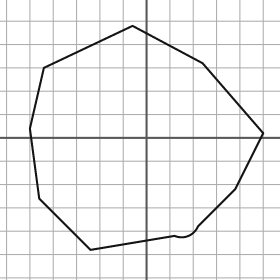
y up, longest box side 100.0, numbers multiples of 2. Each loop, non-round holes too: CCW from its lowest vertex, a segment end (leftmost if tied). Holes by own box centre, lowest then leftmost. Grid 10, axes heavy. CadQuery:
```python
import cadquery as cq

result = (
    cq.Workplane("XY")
    .moveTo(-24.0, -48.0)
    .lineTo(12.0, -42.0)
    .threePointArc((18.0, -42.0), (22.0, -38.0))
    .lineTo(38.0, -22.0)
    .lineTo(50.0, 2.0)
    .lineTo(24.0, 32.0)
    .lineTo(-6.0, 48.0)
    .lineTo(-44.0, 30.0)
    .lineTo(-50.0, 4.0)
    .lineTo(-46.0, -26.0)
    .close()
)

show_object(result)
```